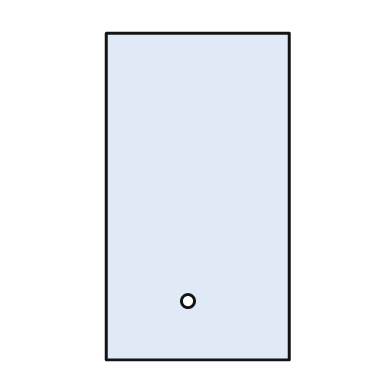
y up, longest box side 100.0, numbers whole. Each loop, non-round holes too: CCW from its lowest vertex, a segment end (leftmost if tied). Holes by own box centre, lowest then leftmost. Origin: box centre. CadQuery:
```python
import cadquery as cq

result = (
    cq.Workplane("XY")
    .moveTo(-28.0, -50.0)
    .lineTo(28.0, -50.0)
    .lineTo(28.0, 50.0)
    .lineTo(-28.0, 50.0)
    .close()
    .moveTo(-3.0, -32.0)
    .circle(2.0)
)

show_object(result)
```